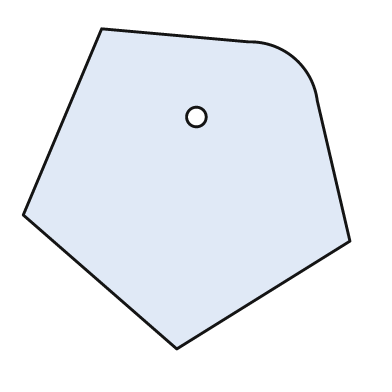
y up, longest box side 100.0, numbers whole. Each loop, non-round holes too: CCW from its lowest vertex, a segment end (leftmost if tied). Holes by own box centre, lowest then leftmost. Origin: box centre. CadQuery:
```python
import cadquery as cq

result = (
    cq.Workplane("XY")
    .moveTo(-3.0, -49.0)
    .lineTo(50.0, -16.0)
    .lineTo(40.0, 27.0)
    .threePointArc((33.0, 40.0), (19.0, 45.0))
    .lineTo(-26.0, 49.0)
    .lineTo(-50.0, -8.0)
    .close()
    .moveTo(3.0, 22.0)
    .circle(3.0)
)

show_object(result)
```